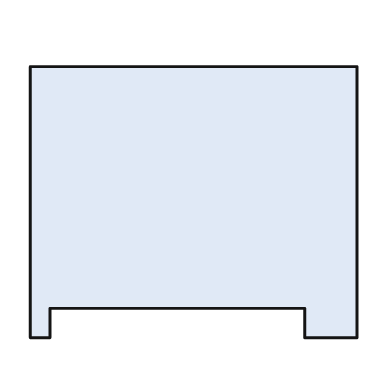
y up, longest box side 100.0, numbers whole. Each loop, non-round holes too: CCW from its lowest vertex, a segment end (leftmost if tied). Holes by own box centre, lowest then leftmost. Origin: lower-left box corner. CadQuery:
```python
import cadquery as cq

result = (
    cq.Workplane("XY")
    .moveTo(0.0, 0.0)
    .lineTo(6.0, 0.0)
    .lineTo(6.0, 9.0)
    .lineTo(84.0, 9.0)
    .lineTo(84.0, 0.0)
    .lineTo(100.0, 0.0)
    .lineTo(100.0, 83.0)
    .lineTo(0.0, 83.0)
    .close()
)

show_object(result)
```